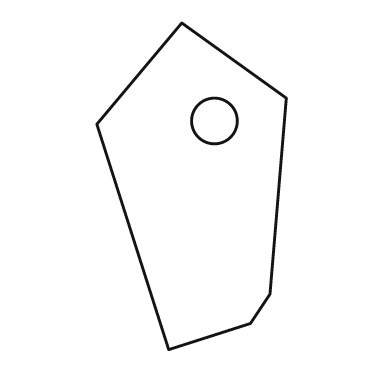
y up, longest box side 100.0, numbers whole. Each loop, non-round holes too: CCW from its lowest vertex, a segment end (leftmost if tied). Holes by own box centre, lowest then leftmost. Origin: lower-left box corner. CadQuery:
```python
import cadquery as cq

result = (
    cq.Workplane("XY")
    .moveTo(22.0, 0.0)
    .lineTo(47.0, 8.0)
    .lineTo(53.0, 17.0)
    .lineTo(58.0, 77.0)
    .lineTo(26.0, 100.0)
    .lineTo(0.0, 69.0)
    .close()
    .moveTo(36.0, 70.0)
    .circle(7.0)
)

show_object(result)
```